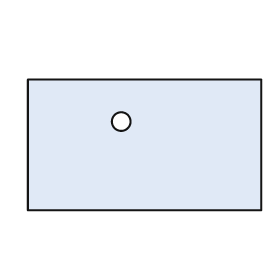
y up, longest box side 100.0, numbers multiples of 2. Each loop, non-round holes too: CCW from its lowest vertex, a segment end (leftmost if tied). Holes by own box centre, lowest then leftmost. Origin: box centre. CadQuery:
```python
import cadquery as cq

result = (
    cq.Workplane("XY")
    .moveTo(-50.0, -28.0)
    .lineTo(50.0, -28.0)
    .lineTo(50.0, 28.0)
    .lineTo(-50.0, 28.0)
    .close()
    .moveTo(-10.0, 10.0)
    .circle(4.0)
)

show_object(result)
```